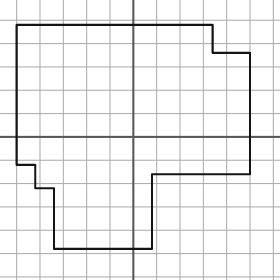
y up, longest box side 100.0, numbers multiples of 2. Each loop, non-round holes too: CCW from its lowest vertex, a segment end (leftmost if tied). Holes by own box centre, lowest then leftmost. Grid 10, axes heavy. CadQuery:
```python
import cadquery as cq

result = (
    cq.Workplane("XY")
    .moveTo(-34.0, -48.0)
    .lineTo(8.0, -48.0)
    .lineTo(8.0, -16.0)
    .lineTo(50.0, -16.0)
    .lineTo(50.0, 36.0)
    .lineTo(34.0, 36.0)
    .lineTo(34.0, 48.0)
    .lineTo(-50.0, 48.0)
    .lineTo(-50.0, -12.0)
    .lineTo(-42.0, -12.0)
    .lineTo(-42.0, -22.0)
    .lineTo(-34.0, -22.0)
    .close()
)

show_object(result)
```